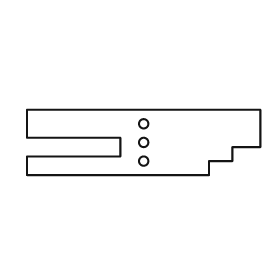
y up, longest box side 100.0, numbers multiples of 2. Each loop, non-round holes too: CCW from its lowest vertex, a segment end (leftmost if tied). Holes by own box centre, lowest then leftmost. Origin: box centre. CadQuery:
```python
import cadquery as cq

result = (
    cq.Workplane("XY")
    .moveTo(-50.0, -14.0)
    .lineTo(28.0, -14.0)
    .lineTo(28.0, -8.0)
    .lineTo(38.0, -8.0)
    .lineTo(38.0, -2.0)
    .lineTo(50.0, -2.0)
    .lineTo(50.0, 14.0)
    .lineTo(-50.0, 14.0)
    .lineTo(-50.0, 2.0)
    .lineTo(-10.0, 2.0)
    .lineTo(-10.0, -6.0)
    .lineTo(-50.0, -6.0)
    .close()
    .moveTo(0.0, -8.0)
    .circle(2.0)
    .moveTo(0.0, 0.0)
    .circle(2.0)
    .moveTo(0.0, 8.0)
    .circle(2.0)
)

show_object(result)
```